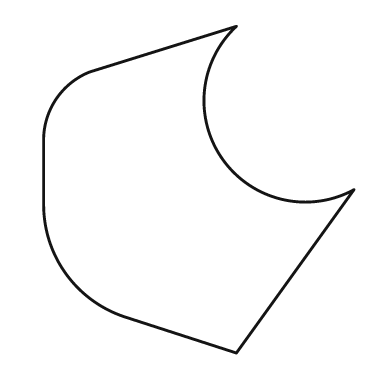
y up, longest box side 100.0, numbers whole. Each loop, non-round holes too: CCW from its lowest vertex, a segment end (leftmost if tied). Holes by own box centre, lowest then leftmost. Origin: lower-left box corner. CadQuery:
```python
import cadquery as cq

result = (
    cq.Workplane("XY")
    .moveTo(59.0, 0.0)
    .lineTo(95.0, 50.0)
    .threePointArc((55.0, 59.0), (59.0, 100.0))
    .lineTo(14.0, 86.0)
    .threePointArc((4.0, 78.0), (0.0, 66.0))
    .lineTo(0.0, 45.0)
    .threePointArc((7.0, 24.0), (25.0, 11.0))
    .close()
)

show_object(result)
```